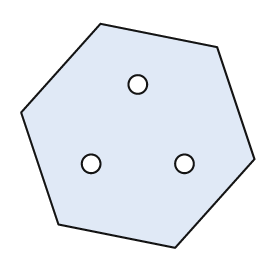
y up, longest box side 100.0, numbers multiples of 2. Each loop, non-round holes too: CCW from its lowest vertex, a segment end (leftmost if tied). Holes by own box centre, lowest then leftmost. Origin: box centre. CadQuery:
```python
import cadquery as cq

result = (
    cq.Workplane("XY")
    .moveTo(16.0, -48.0)
    .lineTo(50.0, -10.0)
    .lineTo(34.0, 38.0)
    .lineTo(-16.0, 48.0)
    .lineTo(-50.0, 10.0)
    .lineTo(-34.0, -38.0)
    .close()
    .moveTo(-20.0, -12.0)
    .circle(4.0)
    .moveTo(20.0, -12.0)
    .circle(4.0)
    .moveTo(0.0, 22.0)
    .circle(4.0)
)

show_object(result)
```